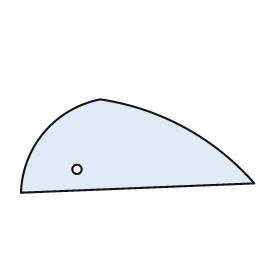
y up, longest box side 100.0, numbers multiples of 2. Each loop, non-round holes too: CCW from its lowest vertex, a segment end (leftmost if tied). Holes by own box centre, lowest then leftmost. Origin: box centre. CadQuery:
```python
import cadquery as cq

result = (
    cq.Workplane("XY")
    .moveTo(-50.0, -20.0)
    .lineTo(50.0, -16.0)
    .threePointArc((20.0, 8.0), (-16.0, 20.0))
    .threePointArc((-40.0, 6.0), (-50.0, -20.0))
    .close()
    .moveTo(-26.0, -10.0)
    .circle(2.0)
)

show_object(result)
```